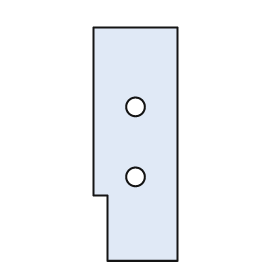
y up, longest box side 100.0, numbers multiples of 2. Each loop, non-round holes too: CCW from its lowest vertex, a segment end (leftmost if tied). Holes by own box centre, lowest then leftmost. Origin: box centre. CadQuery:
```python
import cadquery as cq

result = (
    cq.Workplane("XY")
    .moveTo(-12.0, -50.0)
    .lineTo(18.0, -50.0)
    .lineTo(18.0, 50.0)
    .lineTo(-18.0, 50.0)
    .lineTo(-18.0, -22.0)
    .lineTo(-12.0, -22.0)
    .close()
    .moveTo(0.0, -14.0)
    .circle(4.0)
    .moveTo(0.0, 16.0)
    .circle(4.0)
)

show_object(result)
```